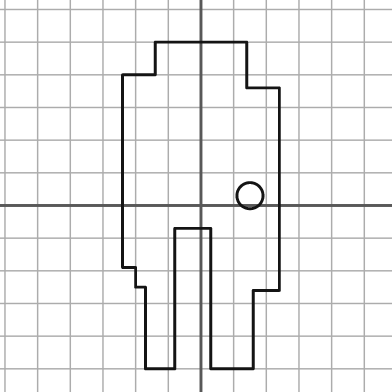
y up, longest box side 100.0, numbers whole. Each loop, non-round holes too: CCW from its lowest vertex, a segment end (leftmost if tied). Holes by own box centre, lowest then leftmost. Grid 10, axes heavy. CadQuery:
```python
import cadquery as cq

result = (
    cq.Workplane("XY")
    .moveTo(-17.0, -50.0)
    .lineTo(-8.0, -50.0)
    .lineTo(-8.0, -7.0)
    .lineTo(3.0, -7.0)
    .lineTo(3.0, -50.0)
    .lineTo(16.0, -50.0)
    .lineTo(16.0, -26.0)
    .lineTo(24.0, -26.0)
    .lineTo(24.0, 36.0)
    .lineTo(14.0, 36.0)
    .lineTo(14.0, 50.0)
    .lineTo(-14.0, 50.0)
    .lineTo(-14.0, 40.0)
    .lineTo(-24.0, 40.0)
    .lineTo(-24.0, -19.0)
    .lineTo(-20.0, -19.0)
    .lineTo(-20.0, -25.0)
    .lineTo(-17.0, -25.0)
    .close()
    .moveTo(15.0, 3.0)
    .circle(4.0)
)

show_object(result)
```